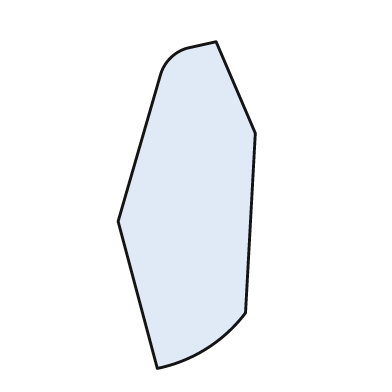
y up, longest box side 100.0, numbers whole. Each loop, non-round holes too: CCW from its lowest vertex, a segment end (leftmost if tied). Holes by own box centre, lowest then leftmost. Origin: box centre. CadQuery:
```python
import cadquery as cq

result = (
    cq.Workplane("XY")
    .moveTo(-9.0, -50.0)
    .threePointArc((6.0, -44.0), (18.0, -33.0))
    .lineTo(21.0, 22.0)
    .lineTo(9.0, 50.0)
    .lineTo(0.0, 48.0)
    .threePointArc((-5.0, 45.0), (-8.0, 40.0))
    .lineTo(-21.0, -5.0)
    .close()
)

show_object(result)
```